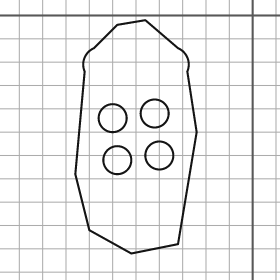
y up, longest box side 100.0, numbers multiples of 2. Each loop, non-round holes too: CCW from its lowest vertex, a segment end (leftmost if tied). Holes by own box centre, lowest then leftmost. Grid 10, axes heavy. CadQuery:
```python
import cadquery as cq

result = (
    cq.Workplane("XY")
    .moveTo(-52.0, -102.0)
    .lineTo(-32.0, -98.0)
    .lineTo(-24.0, -50.0)
    .lineTo(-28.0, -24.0)
    .threePointArc((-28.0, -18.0), (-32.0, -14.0))
    .lineTo(-46.0, -2.0)
    .lineTo(-58.0, -4.0)
    .lineTo(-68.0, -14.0)
    .threePointArc((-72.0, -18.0), (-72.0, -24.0))
    .lineTo(-76.0, -68.0)
    .lineTo(-70.0, -92.0)
    .close()
    .moveTo(-58.0, -62.0)
    .circle(6.0)
    .moveTo(-40.0, -60.0)
    .circle(6.0)
    .moveTo(-60.0, -44.0)
    .circle(6.0)
    .moveTo(-42.0, -42.0)
    .circle(6.0)
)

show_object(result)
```